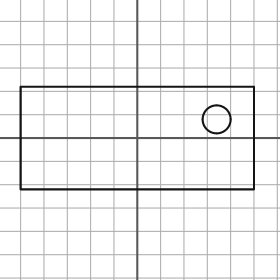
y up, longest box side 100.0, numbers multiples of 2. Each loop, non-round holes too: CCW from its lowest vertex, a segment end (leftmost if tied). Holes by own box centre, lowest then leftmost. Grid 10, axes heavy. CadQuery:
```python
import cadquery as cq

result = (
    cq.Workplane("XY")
    .moveTo(-50.0, -22.0)
    .lineTo(50.0, -22.0)
    .lineTo(50.0, 22.0)
    .lineTo(-50.0, 22.0)
    .close()
    .moveTo(34.0, 8.0)
    .circle(6.0)
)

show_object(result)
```